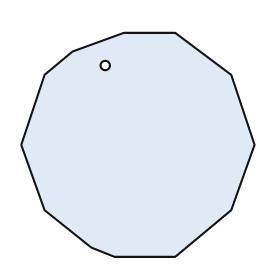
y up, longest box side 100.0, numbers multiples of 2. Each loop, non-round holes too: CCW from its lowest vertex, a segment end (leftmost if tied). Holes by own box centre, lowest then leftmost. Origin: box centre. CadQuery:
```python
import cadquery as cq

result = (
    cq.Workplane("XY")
    .moveTo(-10.0, -48.0)
    .lineTo(16.0, -48.0)
    .lineTo(40.0, -28.0)
    .lineTo(50.0, 0.0)
    .lineTo(40.0, 30.0)
    .lineTo(16.0, 48.0)
    .lineTo(-6.0, 48.0)
    .lineTo(-28.0, 40.0)
    .lineTo(-40.0, 30.0)
    .lineTo(-50.0, 0.0)
    .lineTo(-40.0, -28.0)
    .lineTo(-20.0, -44.0)
    .close()
    .moveTo(-14.0, 34.0)
    .circle(2.0)
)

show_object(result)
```